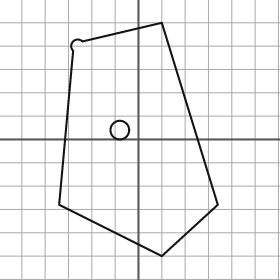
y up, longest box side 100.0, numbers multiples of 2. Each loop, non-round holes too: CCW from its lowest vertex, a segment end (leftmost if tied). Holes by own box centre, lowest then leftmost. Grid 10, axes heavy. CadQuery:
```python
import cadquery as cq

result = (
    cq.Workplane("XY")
    .moveTo(10.0, -50.0)
    .lineTo(34.0, -28.0)
    .lineTo(10.0, 50.0)
    .lineTo(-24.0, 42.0)
    .threePointArc((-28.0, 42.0), (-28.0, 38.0))
    .lineTo(-34.0, -28.0)
    .close()
    .moveTo(-8.0, 4.0)
    .circle(4.0)
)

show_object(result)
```